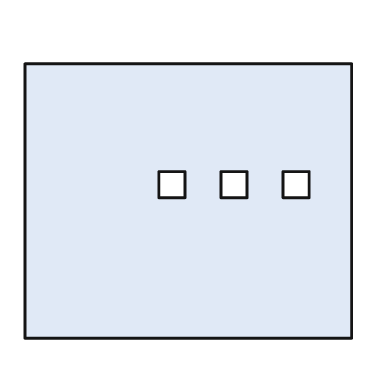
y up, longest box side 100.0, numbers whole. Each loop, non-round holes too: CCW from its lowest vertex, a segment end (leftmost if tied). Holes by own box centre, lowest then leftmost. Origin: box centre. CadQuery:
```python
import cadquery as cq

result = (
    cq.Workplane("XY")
    .moveTo(-50.0, -42.0)
    .lineTo(50.0, -42.0)
    .lineTo(50.0, 42.0)
    .lineTo(-50.0, 42.0)
    .close()
    .moveTo(-9.0, 1.0)
    .lineTo(-1.0, 1.0)
    .lineTo(-1.0, 9.0)
    .lineTo(-9.0, 9.0)
    .close()
    .moveTo(10.0, 1.0)
    .lineTo(18.0, 1.0)
    .lineTo(18.0, 9.0)
    .lineTo(10.0, 9.0)
    .close()
    .moveTo(29.0, 1.0)
    .lineTo(37.0, 1.0)
    .lineTo(37.0, 9.0)
    .lineTo(29.0, 9.0)
    .close()
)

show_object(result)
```